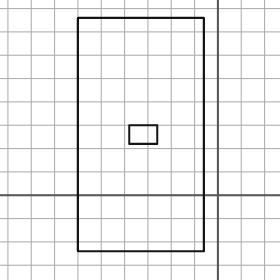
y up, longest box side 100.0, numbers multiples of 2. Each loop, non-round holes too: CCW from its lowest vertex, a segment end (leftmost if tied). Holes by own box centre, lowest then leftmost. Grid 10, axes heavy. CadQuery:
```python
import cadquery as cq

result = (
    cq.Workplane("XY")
    .moveTo(-60.0, -24.0)
    .lineTo(-6.0, -24.0)
    .lineTo(-6.0, 76.0)
    .lineTo(-60.0, 76.0)
    .close()
    .moveTo(-38.0, 22.0)
    .lineTo(-26.0, 22.0)
    .lineTo(-26.0, 30.0)
    .lineTo(-38.0, 30.0)
    .close()
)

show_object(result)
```